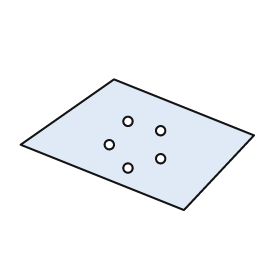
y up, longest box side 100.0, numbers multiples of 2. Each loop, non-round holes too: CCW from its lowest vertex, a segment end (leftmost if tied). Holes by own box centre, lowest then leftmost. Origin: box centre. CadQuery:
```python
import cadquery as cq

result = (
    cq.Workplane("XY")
    .moveTo(20.0, -28.0)
    .lineTo(50.0, 4.0)
    .lineTo(-10.0, 28.0)
    .lineTo(-50.0, 0.0)
    .close()
    .moveTo(-4.0, -10.0)
    .circle(2.0)
    .moveTo(10.0, -6.0)
    .circle(2.0)
    .moveTo(-12.0, 0.0)
    .circle(2.0)
    .moveTo(10.0, 6.0)
    .circle(2.0)
    .moveTo(-4.0, 10.0)
    .circle(2.0)
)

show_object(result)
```